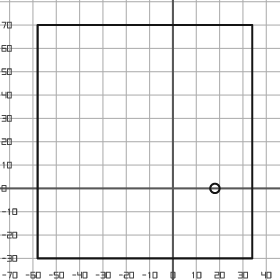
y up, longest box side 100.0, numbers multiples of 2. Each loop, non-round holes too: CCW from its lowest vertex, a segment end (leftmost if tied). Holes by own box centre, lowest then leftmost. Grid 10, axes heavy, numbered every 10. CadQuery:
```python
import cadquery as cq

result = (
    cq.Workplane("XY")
    .moveTo(-58.0, -30.0)
    .lineTo(34.0, -30.0)
    .lineTo(34.0, 70.0)
    .lineTo(-58.0, 70.0)
    .close()
    .moveTo(18.0, 0.0)
    .circle(2.0)
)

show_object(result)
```